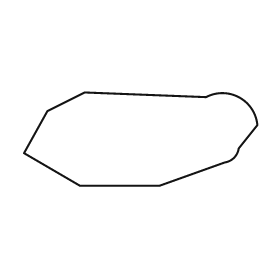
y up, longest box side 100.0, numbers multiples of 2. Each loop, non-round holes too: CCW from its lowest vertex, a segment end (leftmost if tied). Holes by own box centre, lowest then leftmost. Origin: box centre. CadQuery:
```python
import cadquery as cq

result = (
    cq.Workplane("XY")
    .moveTo(-26.0, -20.0)
    .lineTo(8.0, -20.0)
    .lineTo(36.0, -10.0)
    .threePointArc((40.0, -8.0), (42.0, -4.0))
    .lineTo(50.0, 6.0)
    .threePointArc((42.0, 18.0), (28.0, 18.0))
    .lineTo(-24.0, 20.0)
    .lineTo(-40.0, 12.0)
    .lineTo(-50.0, -6.0)
    .close()
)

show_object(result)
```